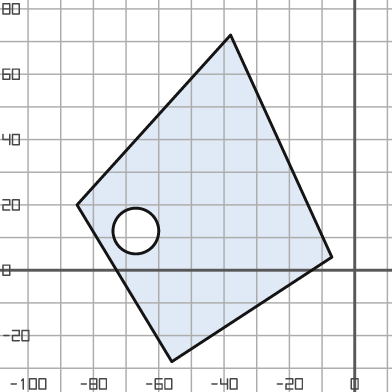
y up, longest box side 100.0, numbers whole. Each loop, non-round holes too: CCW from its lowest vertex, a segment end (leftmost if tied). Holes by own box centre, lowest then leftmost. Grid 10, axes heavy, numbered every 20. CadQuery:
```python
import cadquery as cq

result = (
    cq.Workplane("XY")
    .moveTo(-56.0, -28.0)
    .lineTo(-7.0, 4.0)
    .lineTo(-38.0, 72.0)
    .lineTo(-85.0, 20.0)
    .close()
    .moveTo(-67.0, 12.0)
    .circle(7.0)
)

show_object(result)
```